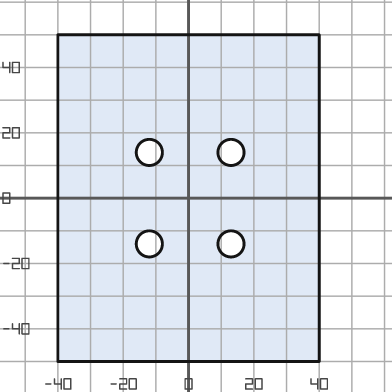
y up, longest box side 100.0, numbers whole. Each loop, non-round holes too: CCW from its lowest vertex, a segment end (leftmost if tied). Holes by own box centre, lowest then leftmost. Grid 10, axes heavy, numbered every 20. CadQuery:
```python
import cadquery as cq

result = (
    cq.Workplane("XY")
    .moveTo(-40.0, -50.0)
    .lineTo(40.0, -50.0)
    .lineTo(40.0, 50.0)
    .lineTo(-40.0, 50.0)
    .close()
    .moveTo(-12.0, -14.0)
    .circle(4.0)
    .moveTo(13.0, -14.0)
    .circle(4.0)
    .moveTo(-12.0, 14.0)
    .circle(4.0)
    .moveTo(13.0, 14.0)
    .circle(4.0)
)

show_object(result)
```